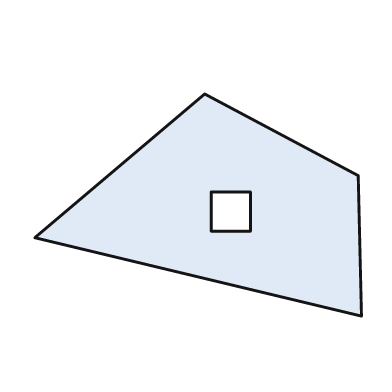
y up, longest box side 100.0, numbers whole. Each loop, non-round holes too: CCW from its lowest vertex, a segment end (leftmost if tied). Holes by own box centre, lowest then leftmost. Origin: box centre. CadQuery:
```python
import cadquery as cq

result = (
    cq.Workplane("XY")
    .moveTo(50.0, -34.0)
    .lineTo(49.0, 9.0)
    .lineTo(2.0, 34.0)
    .lineTo(-50.0, -10.0)
    .close()
    .moveTo(4.0, -8.0)
    .lineTo(16.0, -8.0)
    .lineTo(16.0, 4.0)
    .lineTo(4.0, 4.0)
    .close()
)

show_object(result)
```